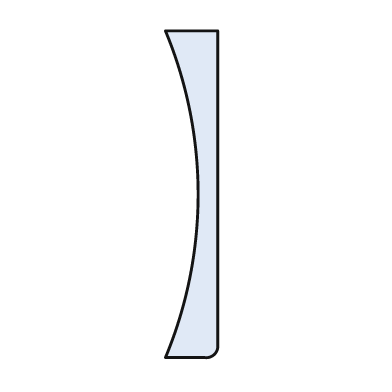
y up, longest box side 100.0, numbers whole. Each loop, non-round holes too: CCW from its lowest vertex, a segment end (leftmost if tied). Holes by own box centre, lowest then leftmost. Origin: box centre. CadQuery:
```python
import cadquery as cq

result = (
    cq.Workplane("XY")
    .moveTo(-8.0, -50.0)
    .lineTo(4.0, -50.0)
    .threePointArc((7.0, -49.0), (8.0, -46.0))
    .lineTo(8.0, 50.0)
    .lineTo(-8.0, 50.0)
    .threePointArc((2.0, 0.0), (-8.0, -50.0))
    .close()
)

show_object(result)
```